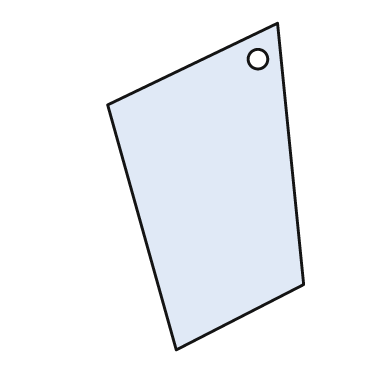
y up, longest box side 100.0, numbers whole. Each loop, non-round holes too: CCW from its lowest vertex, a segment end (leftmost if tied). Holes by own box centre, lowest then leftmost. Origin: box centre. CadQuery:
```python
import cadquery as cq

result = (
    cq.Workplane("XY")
    .moveTo(-9.0, -50.0)
    .lineTo(30.0, -30.0)
    .lineTo(22.0, 50.0)
    .lineTo(-30.0, 25.0)
    .close()
    .moveTo(16.0, 39.0)
    .circle(3.0)
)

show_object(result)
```